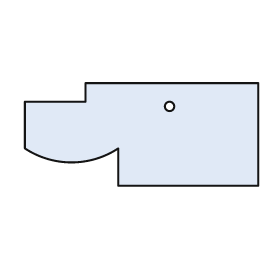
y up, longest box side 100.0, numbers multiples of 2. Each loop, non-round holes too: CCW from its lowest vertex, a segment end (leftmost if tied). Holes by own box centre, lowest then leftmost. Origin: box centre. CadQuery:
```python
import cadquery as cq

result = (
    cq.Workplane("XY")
    .moveTo(-10.0, -22.0)
    .lineTo(50.0, -22.0)
    .lineTo(50.0, 22.0)
    .lineTo(-24.0, 22.0)
    .lineTo(-24.0, 14.0)
    .lineTo(-50.0, 14.0)
    .lineTo(-50.0, -6.0)
    .threePointArc((-30.0, -12.0), (-10.0, -6.0))
    .close()
    .moveTo(12.0, 12.0)
    .circle(2.0)
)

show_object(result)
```